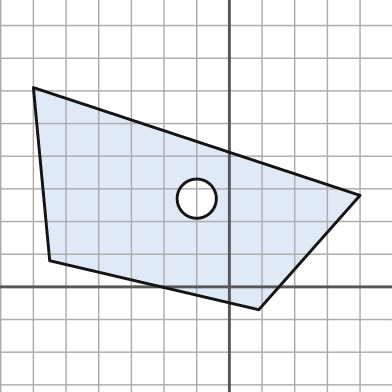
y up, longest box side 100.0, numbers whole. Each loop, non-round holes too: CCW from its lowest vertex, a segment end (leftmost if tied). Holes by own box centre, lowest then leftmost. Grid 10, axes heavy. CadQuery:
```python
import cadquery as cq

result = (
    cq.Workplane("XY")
    .moveTo(9.0, -7.0)
    .lineTo(40.0, 28.0)
    .lineTo(-60.0, 61.0)
    .lineTo(-55.0, 8.0)
    .close()
    .moveTo(-10.0, 27.0)
    .circle(6.0)
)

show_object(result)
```